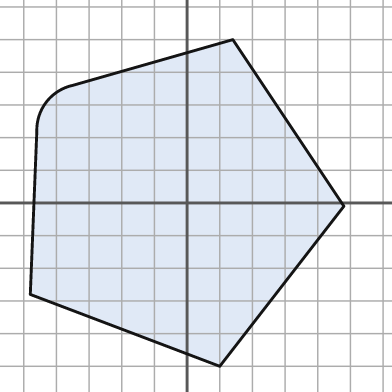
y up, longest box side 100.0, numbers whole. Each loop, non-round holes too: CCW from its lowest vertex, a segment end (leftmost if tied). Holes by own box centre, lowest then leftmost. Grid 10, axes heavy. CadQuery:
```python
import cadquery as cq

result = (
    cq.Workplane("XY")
    .moveTo(10.0, -50.0)
    .lineTo(48.0, -1.0)
    .lineTo(14.0, 50.0)
    .lineTo(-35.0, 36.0)
    .threePointArc((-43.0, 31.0), (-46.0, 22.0))
    .lineTo(-48.0, -28.0)
    .close()
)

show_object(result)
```